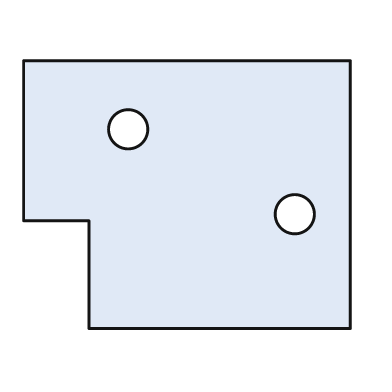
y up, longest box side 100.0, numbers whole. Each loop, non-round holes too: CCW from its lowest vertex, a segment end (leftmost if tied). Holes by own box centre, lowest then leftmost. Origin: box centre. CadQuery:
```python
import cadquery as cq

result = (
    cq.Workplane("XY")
    .moveTo(-30.0, -41.0)
    .lineTo(50.0, -41.0)
    .lineTo(50.0, 41.0)
    .lineTo(-50.0, 41.0)
    .lineTo(-50.0, -8.0)
    .lineTo(-30.0, -8.0)
    .close()
    .moveTo(33.0, -6.0)
    .circle(6.0)
    .moveTo(-18.0, 20.0)
    .circle(6.0)
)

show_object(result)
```